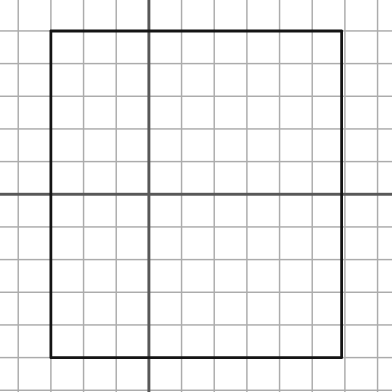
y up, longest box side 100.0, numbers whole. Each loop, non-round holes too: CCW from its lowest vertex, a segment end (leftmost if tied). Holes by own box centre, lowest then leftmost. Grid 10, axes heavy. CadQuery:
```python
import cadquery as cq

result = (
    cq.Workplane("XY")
    .moveTo(-30.0, -50.0)
    .lineTo(59.0, -50.0)
    .lineTo(59.0, 50.0)
    .lineTo(-30.0, 50.0)
    .close()
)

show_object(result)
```